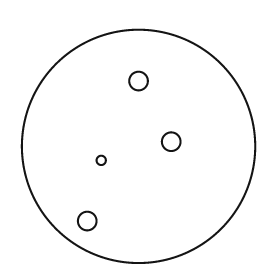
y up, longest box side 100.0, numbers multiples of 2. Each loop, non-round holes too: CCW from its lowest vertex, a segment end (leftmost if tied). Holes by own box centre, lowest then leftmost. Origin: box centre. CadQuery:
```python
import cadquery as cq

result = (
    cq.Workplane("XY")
    .moveTo(0.0, 0.0)
    .circle(50.0)
    .moveTo(-22.0, -32.0)
    .circle(4.0)
    .moveTo(-16.0, -6.0)
    .circle(2.0)
    .moveTo(14.0, 2.0)
    .circle(4.0)
    .moveTo(0.0, 28.0)
    .circle(4.0)
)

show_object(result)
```